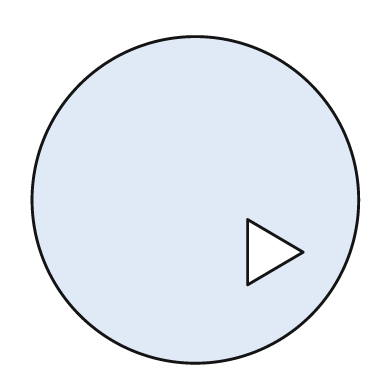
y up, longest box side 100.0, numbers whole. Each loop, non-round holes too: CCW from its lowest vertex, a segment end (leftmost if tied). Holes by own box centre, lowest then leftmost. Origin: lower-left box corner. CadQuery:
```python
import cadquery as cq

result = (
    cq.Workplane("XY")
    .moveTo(50.0, 50.0)
    .circle(50.0)
    .moveTo(66.0, 24.0)
    .lineTo(83.0, 34.0)
    .lineTo(66.0, 44.0)
    .close()
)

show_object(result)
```